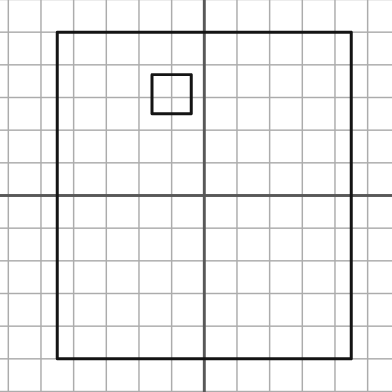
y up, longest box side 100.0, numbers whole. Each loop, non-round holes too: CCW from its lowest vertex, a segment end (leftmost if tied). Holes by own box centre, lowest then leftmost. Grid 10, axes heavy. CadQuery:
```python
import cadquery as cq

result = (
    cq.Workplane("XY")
    .moveTo(-45.0, -50.0)
    .lineTo(45.0, -50.0)
    .lineTo(45.0, 50.0)
    .lineTo(-45.0, 50.0)
    .close()
    .moveTo(-16.0, 25.0)
    .lineTo(-4.0, 25.0)
    .lineTo(-4.0, 37.0)
    .lineTo(-16.0, 37.0)
    .close()
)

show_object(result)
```